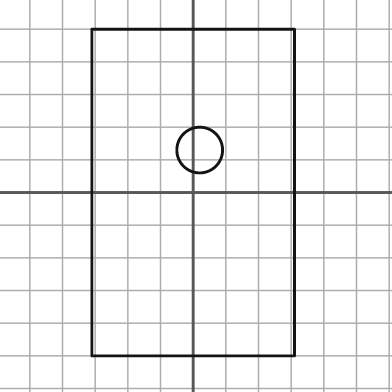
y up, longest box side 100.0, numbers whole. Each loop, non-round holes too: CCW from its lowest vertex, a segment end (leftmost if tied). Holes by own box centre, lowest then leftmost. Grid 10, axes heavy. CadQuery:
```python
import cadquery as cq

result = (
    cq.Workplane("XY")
    .moveTo(-31.0, -50.0)
    .lineTo(31.0, -50.0)
    .lineTo(31.0, 50.0)
    .lineTo(-31.0, 50.0)
    .close()
    .moveTo(2.0, 13.0)
    .circle(7.0)
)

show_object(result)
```